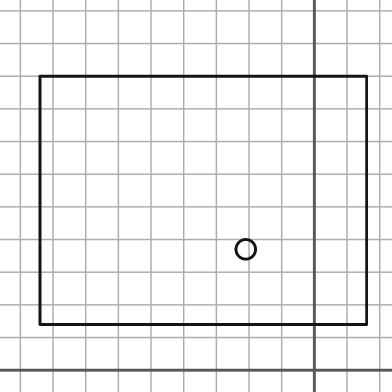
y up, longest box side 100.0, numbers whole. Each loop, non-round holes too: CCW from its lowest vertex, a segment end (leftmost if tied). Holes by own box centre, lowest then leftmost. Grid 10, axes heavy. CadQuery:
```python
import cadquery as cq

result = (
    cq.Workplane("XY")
    .moveTo(-84.0, 14.0)
    .lineTo(16.0, 14.0)
    .lineTo(16.0, 90.0)
    .lineTo(-84.0, 90.0)
    .close()
    .moveTo(-21.0, 37.0)
    .circle(3.0)
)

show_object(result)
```